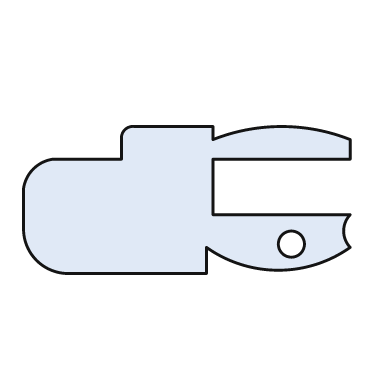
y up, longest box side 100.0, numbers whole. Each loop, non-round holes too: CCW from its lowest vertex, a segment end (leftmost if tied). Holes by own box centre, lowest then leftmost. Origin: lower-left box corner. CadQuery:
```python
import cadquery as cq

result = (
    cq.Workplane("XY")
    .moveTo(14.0, 0.0)
    .lineTo(56.0, 0.0)
    .lineTo(56.0, 8.0)
    .threePointArc((78.0, 1.0), (100.0, 8.0))
    .threePointArc((98.0, 13.0), (100.0, 18.0))
    .lineTo(58.0, 18.0)
    .lineTo(58.0, 35.0)
    .lineTo(100.0, 35.0)
    .lineTo(100.0, 41.0)
    .threePointArc((79.0, 45.0), (58.0, 41.0))
    .lineTo(58.0, 45.0)
    .lineTo(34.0, 45.0)
    .threePointArc((31.0, 44.0), (30.0, 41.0))
    .lineTo(30.0, 35.0)
    .lineTo(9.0, 35.0)
    .threePointArc((3.0, 32.0), (0.0, 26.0))
    .lineTo(0.0, 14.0)
    .threePointArc((4.0, 4.0), (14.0, 0.0))
    .close()
    .moveTo(82.0, 9.0)
    .circle(4.0)
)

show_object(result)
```